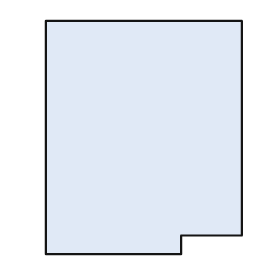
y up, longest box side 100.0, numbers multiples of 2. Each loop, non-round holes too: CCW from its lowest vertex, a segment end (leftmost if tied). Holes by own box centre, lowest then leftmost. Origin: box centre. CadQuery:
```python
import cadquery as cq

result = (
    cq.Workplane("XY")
    .moveTo(-42.0, -50.0)
    .lineTo(16.0, -50.0)
    .lineTo(16.0, -42.0)
    .lineTo(42.0, -42.0)
    .lineTo(42.0, 50.0)
    .lineTo(-42.0, 50.0)
    .close()
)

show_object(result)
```